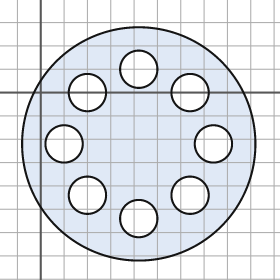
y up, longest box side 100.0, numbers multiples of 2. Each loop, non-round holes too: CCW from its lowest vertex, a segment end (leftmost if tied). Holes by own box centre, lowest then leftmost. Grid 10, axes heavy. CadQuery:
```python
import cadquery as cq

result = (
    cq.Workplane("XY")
    .moveTo(42.0, -22.0)
    .circle(50.0)
    .moveTo(42.0, -54.0)
    .circle(8.0)
    .moveTo(20.0, -44.0)
    .circle(8.0)
    .moveTo(64.0, -44.0)
    .circle(8.0)
    .moveTo(10.0, -22.0)
    .circle(8.0)
    .moveTo(74.0, -22.0)
    .circle(8.0)
    .moveTo(20.0, 0.0)
    .circle(8.0)
    .moveTo(64.0, 0.0)
    .circle(8.0)
    .moveTo(42.0, 10.0)
    .circle(8.0)
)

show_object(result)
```